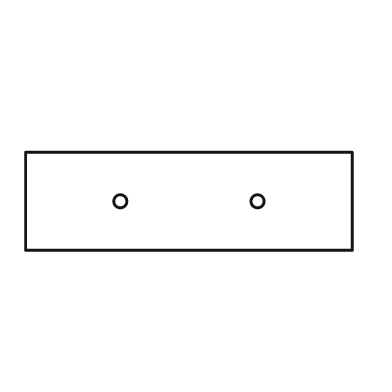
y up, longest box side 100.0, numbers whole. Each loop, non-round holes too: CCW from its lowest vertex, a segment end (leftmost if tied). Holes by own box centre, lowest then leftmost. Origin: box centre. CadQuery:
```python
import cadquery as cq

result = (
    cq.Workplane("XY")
    .moveTo(-50.0, -15.0)
    .lineTo(50.0, -15.0)
    .lineTo(50.0, 15.0)
    .lineTo(-50.0, 15.0)
    .close()
    .moveTo(-21.0, 0.0)
    .circle(2.0)
    .moveTo(21.0, 0.0)
    .circle(2.0)
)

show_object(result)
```